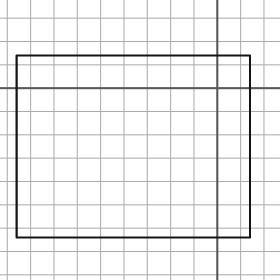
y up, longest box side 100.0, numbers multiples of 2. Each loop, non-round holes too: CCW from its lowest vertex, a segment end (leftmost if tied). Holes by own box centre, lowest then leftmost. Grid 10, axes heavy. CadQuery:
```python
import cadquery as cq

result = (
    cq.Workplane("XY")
    .moveTo(-86.0, -64.0)
    .lineTo(14.0, -64.0)
    .lineTo(14.0, 14.0)
    .lineTo(-86.0, 14.0)
    .close()
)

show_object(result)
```